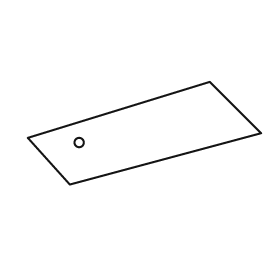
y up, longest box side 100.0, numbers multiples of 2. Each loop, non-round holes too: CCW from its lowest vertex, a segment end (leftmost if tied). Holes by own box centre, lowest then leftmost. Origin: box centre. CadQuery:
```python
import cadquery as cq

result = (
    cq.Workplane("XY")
    .moveTo(-32.0, -22.0)
    .lineTo(50.0, 0.0)
    .lineTo(28.0, 22.0)
    .lineTo(-50.0, -2.0)
    .close()
    .moveTo(-28.0, -4.0)
    .circle(2.0)
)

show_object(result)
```